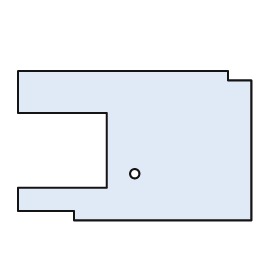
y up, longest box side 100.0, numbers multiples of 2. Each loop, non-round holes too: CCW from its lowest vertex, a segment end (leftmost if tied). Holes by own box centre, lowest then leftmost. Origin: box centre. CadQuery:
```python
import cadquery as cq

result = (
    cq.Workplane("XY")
    .moveTo(-26.0, -32.0)
    .lineTo(50.0, -32.0)
    .lineTo(50.0, 28.0)
    .lineTo(40.0, 28.0)
    .lineTo(40.0, 32.0)
    .lineTo(-50.0, 32.0)
    .lineTo(-50.0, 14.0)
    .lineTo(-12.0, 14.0)
    .lineTo(-12.0, -18.0)
    .lineTo(-50.0, -18.0)
    .lineTo(-50.0, -28.0)
    .lineTo(-26.0, -28.0)
    .close()
    .moveTo(0.0, -12.0)
    .circle(2.0)
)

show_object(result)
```